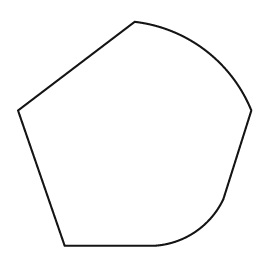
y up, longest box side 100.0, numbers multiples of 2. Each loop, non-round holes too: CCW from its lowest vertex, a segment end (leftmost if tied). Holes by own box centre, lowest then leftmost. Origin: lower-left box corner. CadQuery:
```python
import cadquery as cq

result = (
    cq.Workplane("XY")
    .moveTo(20.0, 0.0)
    .lineTo(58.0, 0.0)
    .threePointArc((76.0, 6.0), (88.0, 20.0))
    .lineTo(100.0, 58.0)
    .threePointArc((80.0, 84.0), (50.0, 96.0))
    .lineTo(0.0, 58.0)
    .close()
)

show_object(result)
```